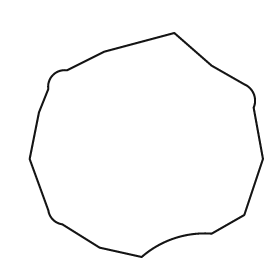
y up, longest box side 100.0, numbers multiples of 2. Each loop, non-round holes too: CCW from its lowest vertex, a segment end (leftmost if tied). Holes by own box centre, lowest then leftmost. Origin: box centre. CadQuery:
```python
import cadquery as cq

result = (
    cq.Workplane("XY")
    .moveTo(-2.0, -48.0)
    .threePointArc((12.0, -40.0), (28.0, -38.0))
    .lineTo(42.0, -30.0)
    .lineTo(50.0, -6.0)
    .lineTo(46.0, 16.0)
    .threePointArc((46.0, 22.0), (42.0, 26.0))
    .lineTo(28.0, 34.0)
    .lineTo(12.0, 48.0)
    .lineTo(-18.0, 40.0)
    .lineTo(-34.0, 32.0)
    .threePointArc((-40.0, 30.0), (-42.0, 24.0))
    .lineTo(-46.0, 14.0)
    .lineTo(-50.0, -6.0)
    .lineTo(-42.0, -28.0)
    .threePointArc((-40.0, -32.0), (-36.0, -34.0))
    .lineTo(-20.0, -44.0)
    .close()
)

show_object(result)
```